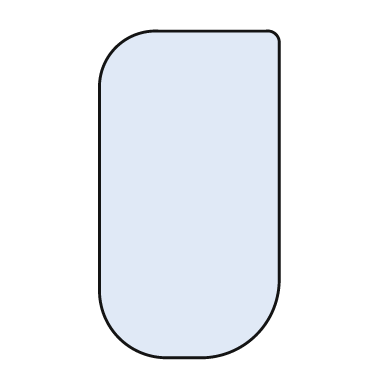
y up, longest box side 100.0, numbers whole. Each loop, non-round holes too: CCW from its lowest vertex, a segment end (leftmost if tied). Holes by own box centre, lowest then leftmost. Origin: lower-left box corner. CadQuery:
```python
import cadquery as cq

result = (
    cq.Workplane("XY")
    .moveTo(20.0, 0.0)
    .lineTo(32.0, 0.0)
    .threePointArc((48.0, 7.0), (55.0, 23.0))
    .lineTo(55.0, 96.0)
    .threePointArc((54.0, 99.0), (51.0, 100.0))
    .lineTo(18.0, 100.0)
    .threePointArc((5.0, 95.0), (0.0, 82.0))
    .lineTo(0.0, 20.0)
    .threePointArc((6.0, 6.0), (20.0, 0.0))
    .close()
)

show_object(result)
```